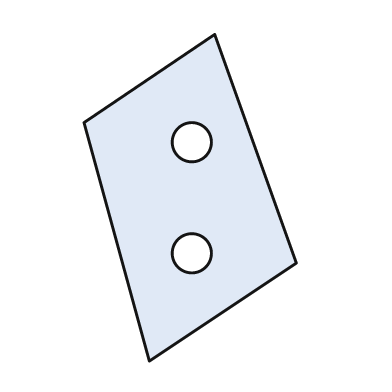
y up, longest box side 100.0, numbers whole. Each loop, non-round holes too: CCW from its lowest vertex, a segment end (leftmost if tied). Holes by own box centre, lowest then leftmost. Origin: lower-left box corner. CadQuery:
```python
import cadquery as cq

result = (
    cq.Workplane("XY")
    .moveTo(20.0, 0.0)
    .lineTo(65.0, 30.0)
    .lineTo(40.0, 100.0)
    .lineTo(0.0, 73.0)
    .close()
    .moveTo(33.0, 33.0)
    .circle(6.0)
    .moveTo(33.0, 67.0)
    .circle(6.0)
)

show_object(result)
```